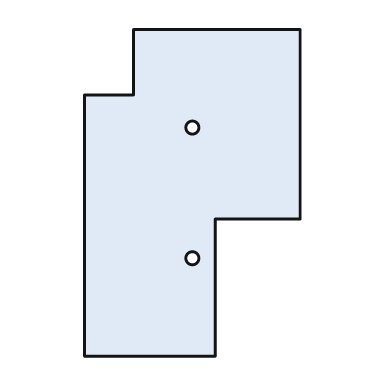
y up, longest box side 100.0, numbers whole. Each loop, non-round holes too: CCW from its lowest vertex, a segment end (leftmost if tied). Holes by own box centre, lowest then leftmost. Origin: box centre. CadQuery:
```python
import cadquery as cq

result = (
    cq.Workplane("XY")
    .moveTo(-33.0, -50.0)
    .lineTo(7.0, -50.0)
    .lineTo(7.0, -8.0)
    .lineTo(33.0, -8.0)
    .lineTo(33.0, 50.0)
    .lineTo(-18.0, 50.0)
    .lineTo(-18.0, 30.0)
    .lineTo(-33.0, 30.0)
    .close()
    .moveTo(0.0, -20.0)
    .circle(2.0)
    .moveTo(0.0, 20.0)
    .circle(2.0)
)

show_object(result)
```